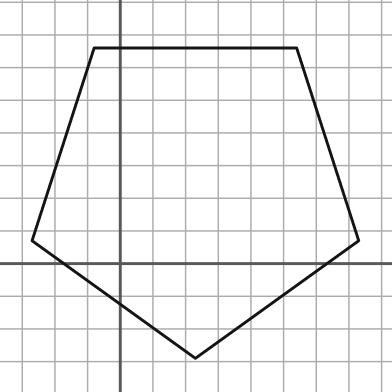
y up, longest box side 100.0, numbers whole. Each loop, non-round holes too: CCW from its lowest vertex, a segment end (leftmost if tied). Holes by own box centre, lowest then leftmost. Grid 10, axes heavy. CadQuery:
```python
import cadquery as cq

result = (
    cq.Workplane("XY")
    .moveTo(23.0, -29.0)
    .lineTo(73.0, 7.0)
    .lineTo(54.0, 66.0)
    .lineTo(-8.0, 66.0)
    .lineTo(-27.0, 7.0)
    .close()
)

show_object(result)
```